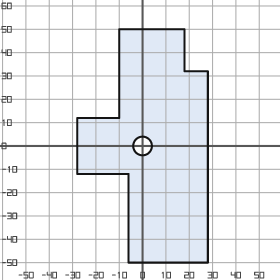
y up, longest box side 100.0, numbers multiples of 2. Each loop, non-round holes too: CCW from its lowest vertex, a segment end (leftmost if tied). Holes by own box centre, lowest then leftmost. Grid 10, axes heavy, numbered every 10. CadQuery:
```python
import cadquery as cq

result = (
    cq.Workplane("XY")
    .moveTo(-6.0, -50.0)
    .lineTo(28.0, -50.0)
    .lineTo(28.0, 32.0)
    .lineTo(18.0, 32.0)
    .lineTo(18.0, 50.0)
    .lineTo(-10.0, 50.0)
    .lineTo(-10.0, 12.0)
    .lineTo(-28.0, 12.0)
    .lineTo(-28.0, -12.0)
    .lineTo(-6.0, -12.0)
    .close()
    .moveTo(0.0, 0.0)
    .circle(4.0)
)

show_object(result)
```